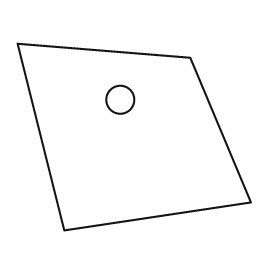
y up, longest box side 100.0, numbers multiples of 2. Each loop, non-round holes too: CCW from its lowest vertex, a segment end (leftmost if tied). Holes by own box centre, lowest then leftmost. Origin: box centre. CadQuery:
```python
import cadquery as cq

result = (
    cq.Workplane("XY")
    .moveTo(-30.0, -40.0)
    .lineTo(50.0, -28.0)
    .lineTo(24.0, 34.0)
    .lineTo(-50.0, 40.0)
    .close()
    .moveTo(-6.0, 16.0)
    .circle(6.0)
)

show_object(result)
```